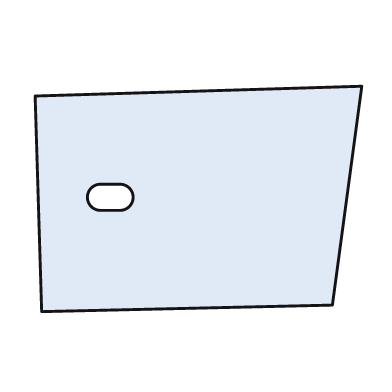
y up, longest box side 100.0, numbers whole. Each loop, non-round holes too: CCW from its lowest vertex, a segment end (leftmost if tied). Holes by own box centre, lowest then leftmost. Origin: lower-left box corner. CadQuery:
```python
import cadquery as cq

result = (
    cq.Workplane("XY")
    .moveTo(2.0, 0.0)
    .lineTo(91.0, 2.0)
    .lineTo(100.0, 69.0)
    .lineTo(0.0, 66.0)
    .close()
    .moveTo(20.0, 31.0)
    .lineTo(26.0, 31.0)
    .threePointArc((30.0, 35.0), (26.0, 39.0))
    .lineTo(20.0, 39.0)
    .threePointArc((16.0, 35.0), (20.0, 31.0))
    .close()
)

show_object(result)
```